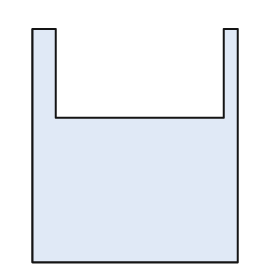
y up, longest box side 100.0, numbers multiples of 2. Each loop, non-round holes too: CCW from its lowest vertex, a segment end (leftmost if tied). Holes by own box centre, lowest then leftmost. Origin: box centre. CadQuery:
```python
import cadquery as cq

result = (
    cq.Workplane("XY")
    .moveTo(-44.0, -50.0)
    .lineTo(44.0, -50.0)
    .lineTo(44.0, 50.0)
    .lineTo(38.0, 50.0)
    .lineTo(38.0, 12.0)
    .lineTo(-34.0, 12.0)
    .lineTo(-34.0, 50.0)
    .lineTo(-44.0, 50.0)
    .close()
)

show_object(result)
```